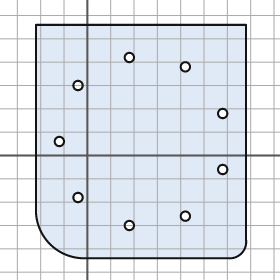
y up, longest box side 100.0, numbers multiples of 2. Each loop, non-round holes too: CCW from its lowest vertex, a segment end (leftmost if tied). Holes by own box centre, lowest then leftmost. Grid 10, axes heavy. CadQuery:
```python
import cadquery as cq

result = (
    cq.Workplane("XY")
    .moveTo(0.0, -44.0)
    .lineTo(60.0, -44.0)
    .threePointArc((66.0, -42.0), (68.0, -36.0))
    .lineTo(68.0, 56.0)
    .lineTo(-22.0, 56.0)
    .lineTo(-22.0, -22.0)
    .threePointArc((-16.0, -38.0), (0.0, -44.0))
    .close()
    .moveTo(18.0, -30.0)
    .circle(2.0)
    .moveTo(42.0, -26.0)
    .circle(2.0)
    .moveTo(-4.0, -18.0)
    .circle(2.0)
    .moveTo(58.0, -6.0)
    .circle(2.0)
    .moveTo(-12.0, 6.0)
    .circle(2.0)
    .moveTo(58.0, 18.0)
    .circle(2.0)
    .moveTo(-4.0, 30.0)
    .circle(2.0)
    .moveTo(42.0, 38.0)
    .circle(2.0)
    .moveTo(18.0, 42.0)
    .circle(2.0)
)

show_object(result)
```